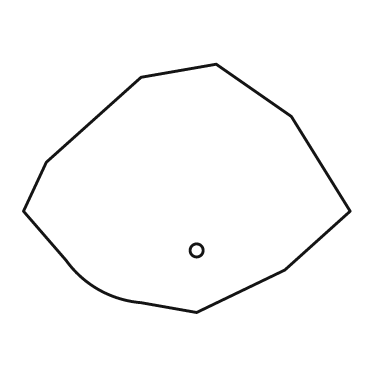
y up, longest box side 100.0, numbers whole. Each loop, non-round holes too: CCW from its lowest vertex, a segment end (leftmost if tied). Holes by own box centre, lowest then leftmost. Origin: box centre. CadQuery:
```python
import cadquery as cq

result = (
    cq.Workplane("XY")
    .moveTo(3.0, -38.0)
    .lineTo(30.0, -25.0)
    .lineTo(50.0, -7.0)
    .lineTo(32.0, 22.0)
    .lineTo(9.0, 38.0)
    .lineTo(-14.0, 34.0)
    .lineTo(-43.0, 8.0)
    .lineTo(-50.0, -7.0)
    .lineTo(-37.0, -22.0)
    .threePointArc((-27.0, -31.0), (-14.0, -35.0))
    .close()
    .moveTo(3.0, -19.0)
    .circle(2.0)
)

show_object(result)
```